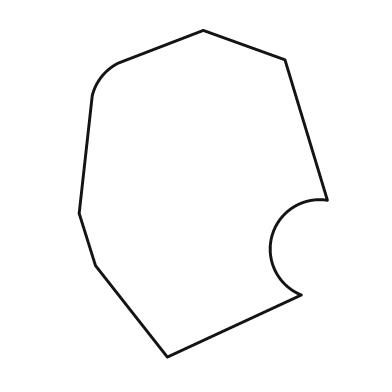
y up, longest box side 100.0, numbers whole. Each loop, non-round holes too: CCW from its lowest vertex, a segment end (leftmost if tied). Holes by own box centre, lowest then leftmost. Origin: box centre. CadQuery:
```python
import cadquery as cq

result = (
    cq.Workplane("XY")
    .moveTo(-11.0, -50.0)
    .lineTo(30.0, -31.0)
    .threePointArc((21.0, -13.0), (38.0, -2.0))
    .lineTo(25.0, 41.0)
    .lineTo(0.0, 50.0)
    .lineTo(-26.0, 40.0)
    .threePointArc((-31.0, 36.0), (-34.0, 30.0))
    .lineTo(-38.0, -6.0)
    .lineTo(-33.0, -22.0)
    .close()
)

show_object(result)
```